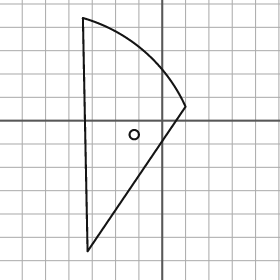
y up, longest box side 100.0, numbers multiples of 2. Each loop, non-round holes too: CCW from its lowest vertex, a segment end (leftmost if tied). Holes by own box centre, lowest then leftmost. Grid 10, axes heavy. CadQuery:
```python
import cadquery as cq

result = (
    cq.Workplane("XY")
    .moveTo(-32.0, -56.0)
    .lineTo(10.0, 6.0)
    .threePointArc((-8.0, 30.0), (-34.0, 44.0))
    .close()
    .moveTo(-12.0, -6.0)
    .circle(2.0)
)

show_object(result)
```